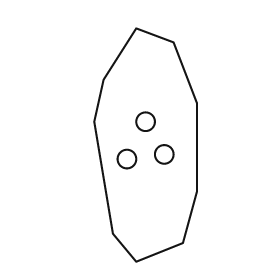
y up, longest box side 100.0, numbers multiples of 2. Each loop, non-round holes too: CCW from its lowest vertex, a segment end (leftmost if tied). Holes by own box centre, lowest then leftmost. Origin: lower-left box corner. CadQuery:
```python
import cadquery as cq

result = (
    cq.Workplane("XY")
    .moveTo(18.0, 0.0)
    .lineTo(38.0, 8.0)
    .lineTo(44.0, 30.0)
    .lineTo(44.0, 68.0)
    .lineTo(34.0, 94.0)
    .lineTo(18.0, 100.0)
    .lineTo(4.0, 78.0)
    .lineTo(0.0, 60.0)
    .lineTo(8.0, 12.0)
    .close()
    .moveTo(14.0, 44.0)
    .circle(4.0)
    .moveTo(30.0, 46.0)
    .circle(4.0)
    .moveTo(22.0, 60.0)
    .circle(4.0)
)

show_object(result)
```